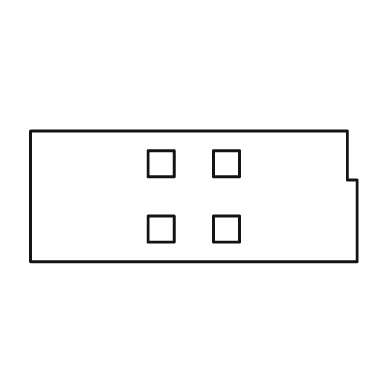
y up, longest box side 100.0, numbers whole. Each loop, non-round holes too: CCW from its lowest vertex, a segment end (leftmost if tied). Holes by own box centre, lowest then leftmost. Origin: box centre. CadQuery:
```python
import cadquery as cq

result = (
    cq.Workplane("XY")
    .moveTo(-50.0, -20.0)
    .lineTo(50.0, -20.0)
    .lineTo(50.0, 5.0)
    .lineTo(47.0, 5.0)
    .lineTo(47.0, 20.0)
    .lineTo(-50.0, 20.0)
    .close()
    .moveTo(-14.0, -14.0)
    .lineTo(-6.0, -14.0)
    .lineTo(-6.0, -6.0)
    .lineTo(-14.0, -6.0)
    .close()
    .moveTo(6.0, -14.0)
    .lineTo(14.0, -14.0)
    .lineTo(14.0, -6.0)
    .lineTo(6.0, -6.0)
    .close()
    .moveTo(-14.0, 6.0)
    .lineTo(-6.0, 6.0)
    .lineTo(-6.0, 14.0)
    .lineTo(-14.0, 14.0)
    .close()
    .moveTo(6.0, 6.0)
    .lineTo(14.0, 6.0)
    .lineTo(14.0, 14.0)
    .lineTo(6.0, 14.0)
    .close()
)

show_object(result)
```